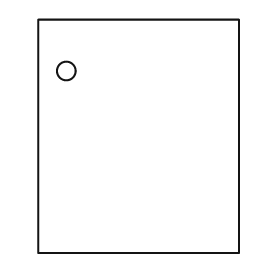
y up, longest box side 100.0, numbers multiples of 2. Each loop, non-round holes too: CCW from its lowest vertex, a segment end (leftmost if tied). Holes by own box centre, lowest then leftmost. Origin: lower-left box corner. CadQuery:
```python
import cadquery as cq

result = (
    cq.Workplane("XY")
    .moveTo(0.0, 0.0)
    .lineTo(86.0, 0.0)
    .lineTo(86.0, 100.0)
    .lineTo(0.0, 100.0)
    .close()
    .moveTo(12.0, 78.0)
    .circle(4.0)
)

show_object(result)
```